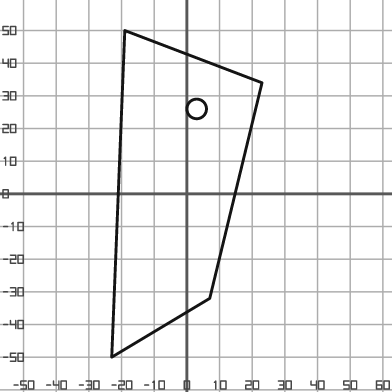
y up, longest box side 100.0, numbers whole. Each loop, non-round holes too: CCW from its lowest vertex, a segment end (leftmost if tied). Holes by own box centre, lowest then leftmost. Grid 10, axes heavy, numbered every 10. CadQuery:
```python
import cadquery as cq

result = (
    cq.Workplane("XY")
    .moveTo(-23.0, -50.0)
    .lineTo(7.0, -32.0)
    .lineTo(23.0, 34.0)
    .lineTo(-19.0, 50.0)
    .close()
    .moveTo(3.0, 26.0)
    .circle(3.0)
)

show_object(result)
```